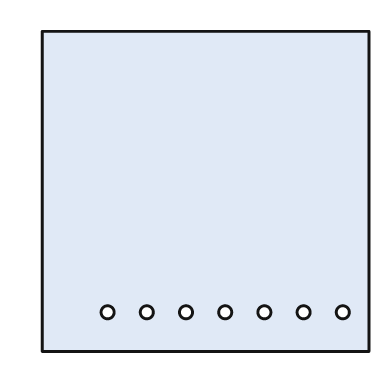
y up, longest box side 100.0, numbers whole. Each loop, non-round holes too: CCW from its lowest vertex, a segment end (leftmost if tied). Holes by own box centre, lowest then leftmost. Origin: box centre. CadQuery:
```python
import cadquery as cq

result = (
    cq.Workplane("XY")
    .moveTo(-50.0, -49.0)
    .lineTo(50.0, -49.0)
    .lineTo(50.0, 49.0)
    .lineTo(-50.0, 49.0)
    .close()
    .moveTo(-30.0, -37.0)
    .circle(2.0)
    .moveTo(-18.0, -37.0)
    .circle(2.0)
    .moveTo(-6.0, -37.0)
    .circle(2.0)
    .moveTo(6.0, -37.0)
    .circle(2.0)
    .moveTo(18.0, -37.0)
    .circle(2.0)
    .moveTo(30.0, -37.0)
    .circle(2.0)
    .moveTo(42.0, -37.0)
    .circle(2.0)
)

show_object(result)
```